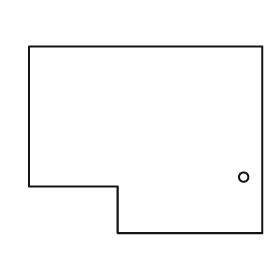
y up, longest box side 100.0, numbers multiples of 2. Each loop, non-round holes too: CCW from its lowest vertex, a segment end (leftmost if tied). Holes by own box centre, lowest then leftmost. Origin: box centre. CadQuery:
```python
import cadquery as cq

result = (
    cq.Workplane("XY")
    .moveTo(-12.0, -40.0)
    .lineTo(50.0, -40.0)
    .lineTo(50.0, 40.0)
    .lineTo(-50.0, 40.0)
    .lineTo(-50.0, -20.0)
    .lineTo(-12.0, -20.0)
    .close()
    .moveTo(42.0, -16.0)
    .circle(2.0)
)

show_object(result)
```